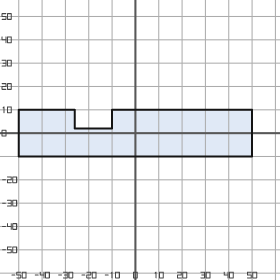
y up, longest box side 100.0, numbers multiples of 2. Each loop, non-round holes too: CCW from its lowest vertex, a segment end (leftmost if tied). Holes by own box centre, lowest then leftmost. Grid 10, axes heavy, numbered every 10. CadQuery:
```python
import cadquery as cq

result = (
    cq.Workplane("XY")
    .moveTo(-50.0, -10.0)
    .lineTo(50.0, -10.0)
    .lineTo(50.0, 10.0)
    .lineTo(-10.0, 10.0)
    .lineTo(-10.0, 2.0)
    .lineTo(-26.0, 2.0)
    .lineTo(-26.0, 10.0)
    .lineTo(-50.0, 10.0)
    .close()
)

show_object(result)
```